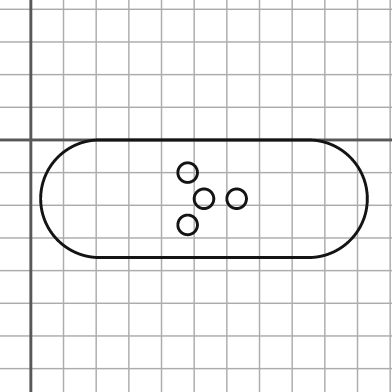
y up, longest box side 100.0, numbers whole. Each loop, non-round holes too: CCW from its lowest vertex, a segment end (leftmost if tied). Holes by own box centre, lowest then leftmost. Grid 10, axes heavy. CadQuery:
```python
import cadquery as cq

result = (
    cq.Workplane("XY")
    .moveTo(21.0, -36.0)
    .lineTo(85.0, -36.0)
    .threePointArc((103.0, -18.0), (85.0, 0.0))
    .lineTo(21.0, 0.0)
    .threePointArc((3.0, -18.0), (21.0, -36.0))
    .close()
    .moveTo(48.0, -26.0)
    .circle(3.0)
    .moveTo(53.0, -18.0)
    .circle(3.0)
    .moveTo(63.0, -18.0)
    .circle(3.0)
    .moveTo(48.0, -10.0)
    .circle(3.0)
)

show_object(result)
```